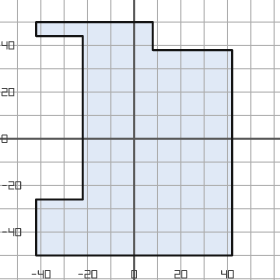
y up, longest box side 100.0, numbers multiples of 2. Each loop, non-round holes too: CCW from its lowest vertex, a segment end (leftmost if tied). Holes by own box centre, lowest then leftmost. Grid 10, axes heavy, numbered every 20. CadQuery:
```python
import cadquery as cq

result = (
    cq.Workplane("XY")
    .moveTo(-42.0, -50.0)
    .lineTo(42.0, -50.0)
    .lineTo(42.0, 38.0)
    .lineTo(8.0, 38.0)
    .lineTo(8.0, 50.0)
    .lineTo(-42.0, 50.0)
    .lineTo(-42.0, 44.0)
    .lineTo(-22.0, 44.0)
    .lineTo(-22.0, -26.0)
    .lineTo(-42.0, -26.0)
    .close()
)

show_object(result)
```